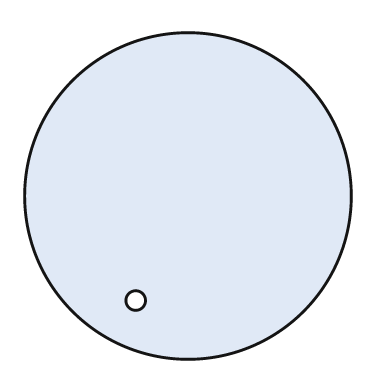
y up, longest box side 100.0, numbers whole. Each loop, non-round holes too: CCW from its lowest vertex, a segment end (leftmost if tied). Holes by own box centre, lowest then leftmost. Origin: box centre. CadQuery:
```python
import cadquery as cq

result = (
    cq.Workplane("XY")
    .moveTo(0.0, 0.0)
    .circle(50.0)
    .moveTo(-16.0, -32.0)
    .circle(3.0)
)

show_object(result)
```